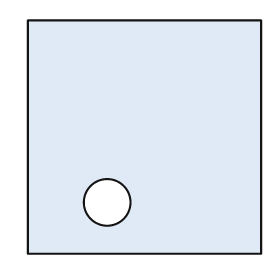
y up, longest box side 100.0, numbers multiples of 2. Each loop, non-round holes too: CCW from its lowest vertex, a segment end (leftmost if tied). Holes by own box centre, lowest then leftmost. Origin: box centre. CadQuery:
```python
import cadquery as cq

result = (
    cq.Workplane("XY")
    .moveTo(-50.0, -50.0)
    .lineTo(50.0, -50.0)
    .lineTo(50.0, 50.0)
    .lineTo(-50.0, 50.0)
    .close()
    .moveTo(-16.0, -28.0)
    .circle(10.0)
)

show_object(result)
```